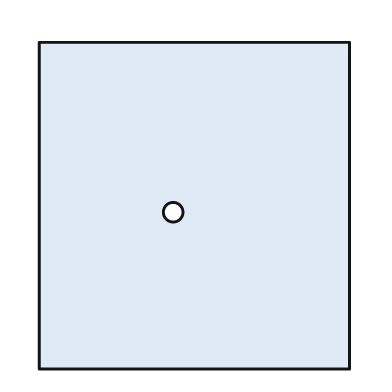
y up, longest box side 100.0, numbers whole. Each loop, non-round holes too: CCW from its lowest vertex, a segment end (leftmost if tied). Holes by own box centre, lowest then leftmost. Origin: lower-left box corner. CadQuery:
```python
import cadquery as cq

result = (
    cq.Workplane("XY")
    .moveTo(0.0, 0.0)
    .lineTo(95.0, 0.0)
    .lineTo(95.0, 100.0)
    .lineTo(0.0, 100.0)
    .close()
    .moveTo(41.0, 48.0)
    .circle(3.0)
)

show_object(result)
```